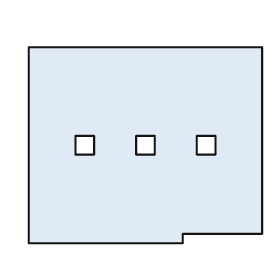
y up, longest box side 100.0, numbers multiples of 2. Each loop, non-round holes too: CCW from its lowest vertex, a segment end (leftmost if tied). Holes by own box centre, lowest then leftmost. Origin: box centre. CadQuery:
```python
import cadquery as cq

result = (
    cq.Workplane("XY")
    .moveTo(-50.0, -42.0)
    .lineTo(16.0, -42.0)
    .lineTo(16.0, -38.0)
    .lineTo(50.0, -38.0)
    .lineTo(50.0, 42.0)
    .lineTo(-50.0, 42.0)
    .close()
    .moveTo(-30.0, -4.0)
    .lineTo(-22.0, -4.0)
    .lineTo(-22.0, 4.0)
    .lineTo(-30.0, 4.0)
    .close()
    .moveTo(-4.0, -4.0)
    .lineTo(4.0, -4.0)
    .lineTo(4.0, 4.0)
    .lineTo(-4.0, 4.0)
    .close()
    .moveTo(22.0, -4.0)
    .lineTo(30.0, -4.0)
    .lineTo(30.0, 4.0)
    .lineTo(22.0, 4.0)
    .close()
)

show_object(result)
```